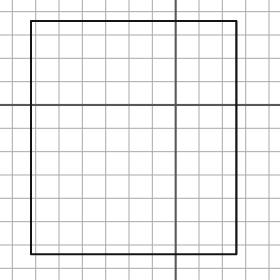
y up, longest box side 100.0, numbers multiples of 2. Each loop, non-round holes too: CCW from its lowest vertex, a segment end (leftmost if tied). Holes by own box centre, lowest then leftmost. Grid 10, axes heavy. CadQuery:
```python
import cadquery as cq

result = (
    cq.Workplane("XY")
    .moveTo(-62.0, -64.0)
    .lineTo(26.0, -64.0)
    .lineTo(26.0, 36.0)
    .lineTo(-62.0, 36.0)
    .close()
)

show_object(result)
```